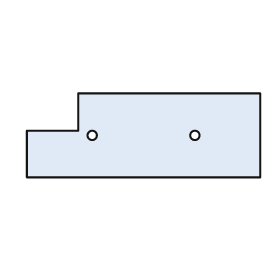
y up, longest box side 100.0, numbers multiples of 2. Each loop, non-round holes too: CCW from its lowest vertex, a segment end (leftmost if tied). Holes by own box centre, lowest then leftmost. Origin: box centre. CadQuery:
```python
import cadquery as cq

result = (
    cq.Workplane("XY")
    .moveTo(-50.0, -18.0)
    .lineTo(50.0, -18.0)
    .lineTo(50.0, 18.0)
    .lineTo(-28.0, 18.0)
    .lineTo(-28.0, 2.0)
    .lineTo(-50.0, 2.0)
    .close()
    .moveTo(-22.0, 0.0)
    .circle(2.0)
    .moveTo(22.0, 0.0)
    .circle(2.0)
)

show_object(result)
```